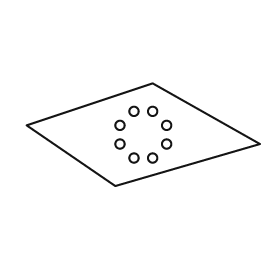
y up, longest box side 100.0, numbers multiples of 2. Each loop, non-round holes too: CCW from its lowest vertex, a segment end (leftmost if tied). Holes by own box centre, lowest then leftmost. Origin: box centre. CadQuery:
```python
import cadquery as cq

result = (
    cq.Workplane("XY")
    .moveTo(-12.0, -22.0)
    .lineTo(50.0, -4.0)
    .lineTo(4.0, 22.0)
    .lineTo(-50.0, 4.0)
    .close()
    .moveTo(-4.0, -10.0)
    .circle(2.0)
    .moveTo(4.0, -10.0)
    .circle(2.0)
    .moveTo(-10.0, -4.0)
    .circle(2.0)
    .moveTo(10.0, -4.0)
    .circle(2.0)
    .moveTo(-10.0, 4.0)
    .circle(2.0)
    .moveTo(10.0, 4.0)
    .circle(2.0)
    .moveTo(-4.0, 10.0)
    .circle(2.0)
    .moveTo(4.0, 10.0)
    .circle(2.0)
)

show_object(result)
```